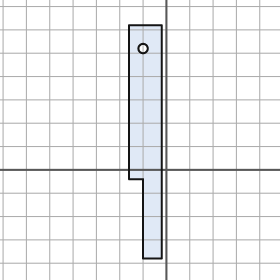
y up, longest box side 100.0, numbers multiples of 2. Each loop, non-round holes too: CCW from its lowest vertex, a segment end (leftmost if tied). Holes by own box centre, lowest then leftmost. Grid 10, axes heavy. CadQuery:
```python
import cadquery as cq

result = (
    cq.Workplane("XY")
    .moveTo(-10.0, -38.0)
    .lineTo(-2.0, -38.0)
    .lineTo(-2.0, 62.0)
    .lineTo(-16.0, 62.0)
    .lineTo(-16.0, -4.0)
    .lineTo(-10.0, -4.0)
    .close()
    .moveTo(-10.0, 52.0)
    .circle(2.0)
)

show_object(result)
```